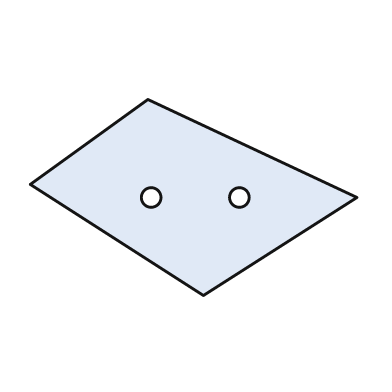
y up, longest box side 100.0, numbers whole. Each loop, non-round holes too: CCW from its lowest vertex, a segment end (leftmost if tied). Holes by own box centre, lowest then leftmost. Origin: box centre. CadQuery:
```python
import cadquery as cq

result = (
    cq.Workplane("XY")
    .moveTo(3.0, -30.0)
    .lineTo(50.0, 0.0)
    .lineTo(-14.0, 30.0)
    .lineTo(-50.0, 4.0)
    .close()
    .moveTo(-13.0, 0.0)
    .circle(3.0)
    .moveTo(14.0, 0.0)
    .circle(3.0)
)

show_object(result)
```